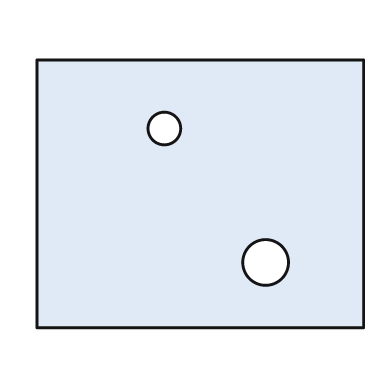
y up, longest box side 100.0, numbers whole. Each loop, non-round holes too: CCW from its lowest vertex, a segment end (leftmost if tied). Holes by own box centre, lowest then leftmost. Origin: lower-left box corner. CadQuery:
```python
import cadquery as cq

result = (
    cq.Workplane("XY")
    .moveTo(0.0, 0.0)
    .lineTo(100.0, 0.0)
    .lineTo(100.0, 82.0)
    .lineTo(0.0, 82.0)
    .close()
    .moveTo(70.0, 20.0)
    .circle(7.0)
    .moveTo(39.0, 61.0)
    .circle(5.0)
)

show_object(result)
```